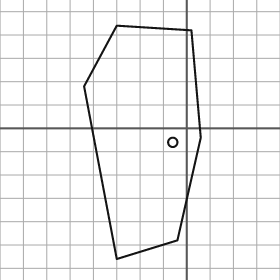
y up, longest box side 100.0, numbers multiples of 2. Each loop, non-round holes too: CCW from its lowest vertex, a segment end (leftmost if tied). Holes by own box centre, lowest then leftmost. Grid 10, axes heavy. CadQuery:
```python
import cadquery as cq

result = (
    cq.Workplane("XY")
    .moveTo(-30.0, -56.0)
    .lineTo(-4.0, -48.0)
    .lineTo(6.0, -4.0)
    .lineTo(2.0, 42.0)
    .lineTo(-30.0, 44.0)
    .lineTo(-44.0, 18.0)
    .close()
    .moveTo(-6.0, -6.0)
    .circle(2.0)
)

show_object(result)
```